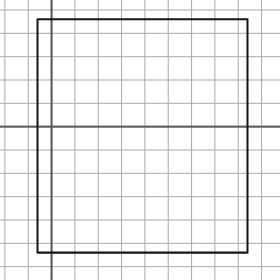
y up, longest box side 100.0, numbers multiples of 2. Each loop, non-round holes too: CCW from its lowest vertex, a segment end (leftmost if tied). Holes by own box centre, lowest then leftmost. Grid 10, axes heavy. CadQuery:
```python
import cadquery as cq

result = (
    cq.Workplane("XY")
    .moveTo(-6.0, -54.0)
    .lineTo(84.0, -54.0)
    .lineTo(84.0, 46.0)
    .lineTo(-6.0, 46.0)
    .close()
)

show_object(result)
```